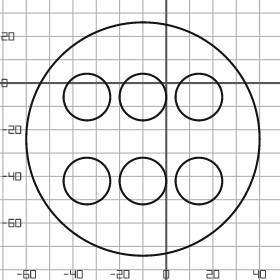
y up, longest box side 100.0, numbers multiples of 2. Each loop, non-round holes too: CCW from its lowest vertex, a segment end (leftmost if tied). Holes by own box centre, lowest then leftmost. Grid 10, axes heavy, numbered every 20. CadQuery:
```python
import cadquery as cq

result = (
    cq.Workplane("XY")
    .moveTo(-10.0, -24.0)
    .circle(50.0)
    .moveTo(-34.0, -42.0)
    .circle(10.0)
    .moveTo(-10.0, -42.0)
    .circle(10.0)
    .moveTo(14.0, -42.0)
    .circle(10.0)
    .moveTo(-34.0, -6.0)
    .circle(10.0)
    .moveTo(-10.0, -6.0)
    .circle(10.0)
    .moveTo(14.0, -6.0)
    .circle(10.0)
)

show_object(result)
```